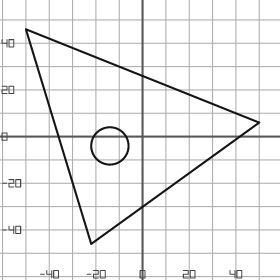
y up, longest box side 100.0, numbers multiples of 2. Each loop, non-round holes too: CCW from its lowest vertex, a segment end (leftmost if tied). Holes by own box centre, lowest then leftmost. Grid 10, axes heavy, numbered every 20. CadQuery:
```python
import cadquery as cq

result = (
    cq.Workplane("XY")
    .moveTo(-22.0, -46.0)
    .lineTo(50.0, 6.0)
    .lineTo(-50.0, 46.0)
    .close()
    .moveTo(-14.0, -4.0)
    .circle(8.0)
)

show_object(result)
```